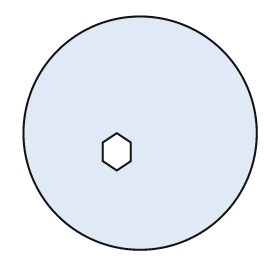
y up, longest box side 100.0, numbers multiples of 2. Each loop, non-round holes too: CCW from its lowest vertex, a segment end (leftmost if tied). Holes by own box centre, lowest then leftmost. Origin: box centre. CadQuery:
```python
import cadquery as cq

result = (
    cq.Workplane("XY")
    .moveTo(0.0, 0.0)
    .circle(50.0)
    .moveTo(-10.0, -16.0)
    .lineTo(-4.0, -12.0)
    .lineTo(-4.0, -4.0)
    .lineTo(-10.0, 0.0)
    .lineTo(-16.0, -4.0)
    .lineTo(-16.0, -12.0)
    .close()
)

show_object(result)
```